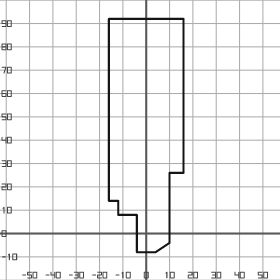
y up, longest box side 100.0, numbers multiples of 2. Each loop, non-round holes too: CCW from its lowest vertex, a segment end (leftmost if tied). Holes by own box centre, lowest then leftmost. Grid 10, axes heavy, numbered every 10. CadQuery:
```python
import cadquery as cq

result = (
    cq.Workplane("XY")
    .moveTo(-4.0, -8.0)
    .lineTo(4.0, -8.0)
    .lineTo(10.0, -4.0)
    .lineTo(10.0, 26.0)
    .lineTo(16.0, 26.0)
    .lineTo(16.0, 92.0)
    .lineTo(-16.0, 92.0)
    .lineTo(-16.0, 14.0)
    .lineTo(-12.0, 14.0)
    .lineTo(-12.0, 8.0)
    .lineTo(-4.0, 8.0)
    .close()
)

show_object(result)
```